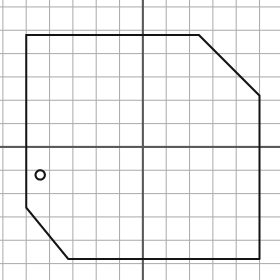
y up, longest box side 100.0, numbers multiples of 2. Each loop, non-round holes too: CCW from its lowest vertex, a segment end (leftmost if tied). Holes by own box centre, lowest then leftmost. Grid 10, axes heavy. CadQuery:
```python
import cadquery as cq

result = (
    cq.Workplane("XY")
    .moveTo(-32.0, -48.0)
    .lineTo(50.0, -48.0)
    .lineTo(50.0, 22.0)
    .lineTo(24.0, 48.0)
    .lineTo(-50.0, 48.0)
    .lineTo(-50.0, -26.0)
    .close()
    .moveTo(-44.0, -12.0)
    .circle(2.0)
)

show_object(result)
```